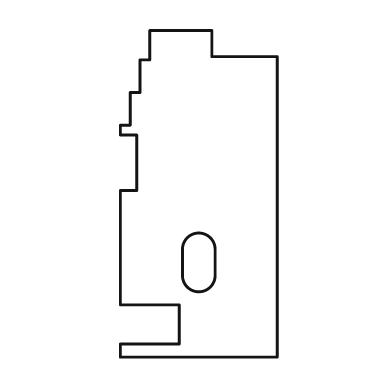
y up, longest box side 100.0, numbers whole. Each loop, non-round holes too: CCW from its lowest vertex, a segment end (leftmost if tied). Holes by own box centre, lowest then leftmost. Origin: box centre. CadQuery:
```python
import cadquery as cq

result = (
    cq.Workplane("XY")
    .moveTo(-24.0, -50.0)
    .lineTo(24.0, -50.0)
    .lineTo(24.0, 42.0)
    .lineTo(4.0, 42.0)
    .lineTo(4.0, 50.0)
    .lineTo(-15.0, 50.0)
    .lineTo(-15.0, 41.0)
    .lineTo(-18.0, 41.0)
    .lineTo(-18.0, 31.0)
    .lineTo(-21.0, 31.0)
    .lineTo(-21.0, 21.0)
    .lineTo(-24.0, 21.0)
    .lineTo(-24.0, 18.0)
    .lineTo(-19.0, 18.0)
    .lineTo(-19.0, 1.0)
    .lineTo(-24.0, 1.0)
    .lineTo(-24.0, -34.0)
    .lineTo(-6.0, -34.0)
    .lineTo(-6.0, -46.0)
    .lineTo(-24.0, -46.0)
    .close()
    .moveTo(-5.0, -25.0)
    .threePointArc((0.0, -30.0), (5.0, -25.0))
    .lineTo(5.0, -17.0)
    .threePointArc((0.0, -12.0), (-5.0, -17.0))
    .close()
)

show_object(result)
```